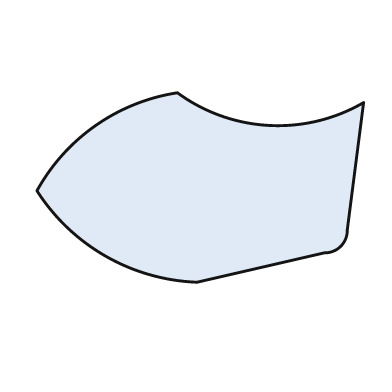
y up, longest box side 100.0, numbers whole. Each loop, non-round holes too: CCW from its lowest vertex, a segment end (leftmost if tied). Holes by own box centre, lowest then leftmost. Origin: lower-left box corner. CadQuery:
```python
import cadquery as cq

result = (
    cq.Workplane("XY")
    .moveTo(49.0, 0.0)
    .lineTo(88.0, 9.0)
    .threePointArc((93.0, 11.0), (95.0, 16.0))
    .lineTo(100.0, 55.0)
    .threePointArc((71.0, 48.0), (43.0, 58.0))
    .threePointArc((18.0, 48.0), (0.0, 28.0))
    .threePointArc((21.0, 8.0), (49.0, 0.0))
    .close()
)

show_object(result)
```